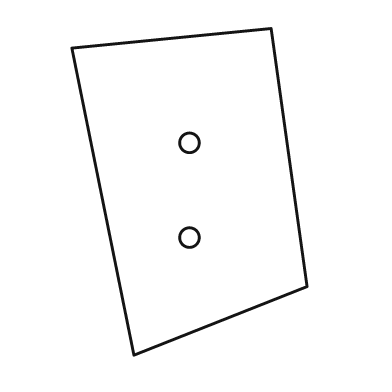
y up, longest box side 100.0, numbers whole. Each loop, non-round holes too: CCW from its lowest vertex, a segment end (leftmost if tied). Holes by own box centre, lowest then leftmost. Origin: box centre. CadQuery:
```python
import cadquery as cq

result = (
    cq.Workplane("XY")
    .moveTo(-17.0, -50.0)
    .lineTo(36.0, -29.0)
    .lineTo(25.0, 50.0)
    .lineTo(-36.0, 44.0)
    .close()
    .moveTo(0.0, -14.0)
    .circle(3.0)
    .moveTo(0.0, 15.0)
    .circle(3.0)
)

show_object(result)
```